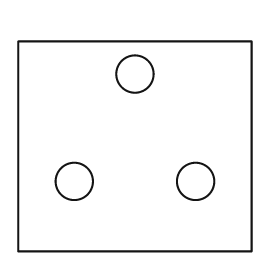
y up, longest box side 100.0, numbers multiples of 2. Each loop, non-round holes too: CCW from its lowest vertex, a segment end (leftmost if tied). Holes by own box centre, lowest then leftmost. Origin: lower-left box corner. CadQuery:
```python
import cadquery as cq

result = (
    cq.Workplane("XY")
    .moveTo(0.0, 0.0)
    .lineTo(100.0, 0.0)
    .lineTo(100.0, 90.0)
    .lineTo(0.0, 90.0)
    .close()
    .moveTo(24.0, 30.0)
    .circle(8.0)
    .moveTo(76.0, 30.0)
    .circle(8.0)
    .moveTo(50.0, 76.0)
    .circle(8.0)
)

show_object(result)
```